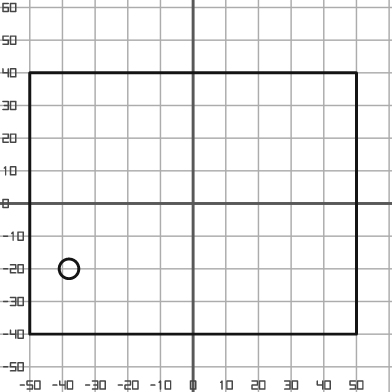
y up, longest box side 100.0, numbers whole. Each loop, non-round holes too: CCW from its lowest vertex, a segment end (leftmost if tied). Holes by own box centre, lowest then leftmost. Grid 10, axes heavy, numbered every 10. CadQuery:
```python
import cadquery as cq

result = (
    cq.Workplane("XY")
    .moveTo(-50.0, -40.0)
    .lineTo(50.0, -40.0)
    .lineTo(50.0, 40.0)
    .lineTo(-50.0, 40.0)
    .close()
    .moveTo(-38.0, -20.0)
    .circle(3.0)
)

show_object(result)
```